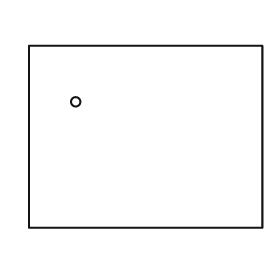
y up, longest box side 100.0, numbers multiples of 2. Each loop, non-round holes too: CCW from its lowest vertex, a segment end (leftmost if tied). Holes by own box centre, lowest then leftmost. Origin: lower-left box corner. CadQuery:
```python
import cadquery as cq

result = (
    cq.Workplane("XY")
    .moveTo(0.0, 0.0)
    .lineTo(100.0, 0.0)
    .lineTo(100.0, 78.0)
    .lineTo(0.0, 78.0)
    .close()
    .moveTo(20.0, 54.0)
    .circle(2.0)
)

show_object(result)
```